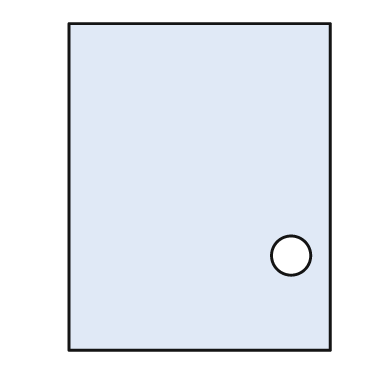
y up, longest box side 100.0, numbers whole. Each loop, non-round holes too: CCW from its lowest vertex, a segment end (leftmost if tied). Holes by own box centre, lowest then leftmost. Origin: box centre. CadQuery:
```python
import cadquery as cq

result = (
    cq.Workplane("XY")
    .moveTo(-40.0, -50.0)
    .lineTo(40.0, -50.0)
    .lineTo(40.0, 50.0)
    .lineTo(-40.0, 50.0)
    .close()
    .moveTo(28.0, -21.0)
    .circle(6.0)
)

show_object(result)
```